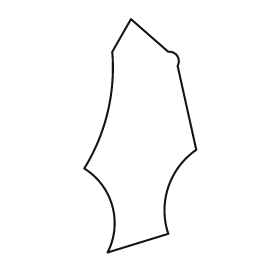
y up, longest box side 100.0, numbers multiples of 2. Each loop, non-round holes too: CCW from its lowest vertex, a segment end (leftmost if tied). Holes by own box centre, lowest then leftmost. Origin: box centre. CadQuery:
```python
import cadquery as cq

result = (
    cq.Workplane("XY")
    .moveTo(-14.0, -50.0)
    .lineTo(12.0, -42.0)
    .threePointArc((12.0, -22.0), (24.0, -6.0))
    .lineTo(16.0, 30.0)
    .threePointArc((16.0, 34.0), (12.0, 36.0))
    .lineTo(-4.0, 50.0)
    .lineTo(-12.0, 36.0)
    .threePointArc((-14.0, 10.0), (-24.0, -14.0))
    .threePointArc((-12.0, -30.0), (-14.0, -50.0))
    .close()
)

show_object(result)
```